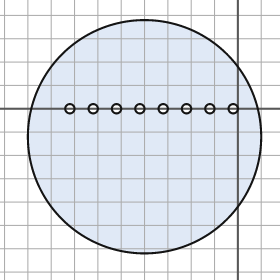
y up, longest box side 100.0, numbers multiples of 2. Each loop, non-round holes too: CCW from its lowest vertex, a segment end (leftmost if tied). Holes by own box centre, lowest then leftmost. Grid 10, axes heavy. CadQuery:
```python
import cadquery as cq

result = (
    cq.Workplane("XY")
    .moveTo(-40.0, -12.0)
    .circle(50.0)
    .moveTo(-72.0, 0.0)
    .circle(2.0)
    .moveTo(-62.0, 0.0)
    .circle(2.0)
    .moveTo(-52.0, 0.0)
    .circle(2.0)
    .moveTo(-42.0, 0.0)
    .circle(2.0)
    .moveTo(-32.0, 0.0)
    .circle(2.0)
    .moveTo(-22.0, 0.0)
    .circle(2.0)
    .moveTo(-12.0, 0.0)
    .circle(2.0)
    .moveTo(-2.0, 0.0)
    .circle(2.0)
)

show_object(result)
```